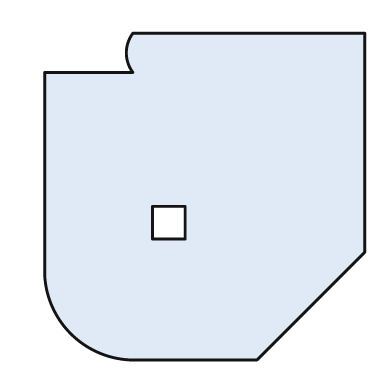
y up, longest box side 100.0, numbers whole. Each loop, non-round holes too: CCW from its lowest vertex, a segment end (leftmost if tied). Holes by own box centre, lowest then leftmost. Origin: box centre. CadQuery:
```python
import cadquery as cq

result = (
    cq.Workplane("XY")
    .moveTo(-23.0, -50.0)
    .lineTo(16.0, -50.0)
    .lineTo(49.0, -17.0)
    .lineTo(49.0, 50.0)
    .lineTo(-22.0, 50.0)
    .threePointArc((-24.0, 44.0), (-22.0, 38.0))
    .lineTo(-49.0, 38.0)
    .lineTo(-49.0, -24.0)
    .threePointArc((-41.0, -42.0), (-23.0, -50.0))
    .close()
    .moveTo(-16.0, -13.0)
    .lineTo(-6.0, -13.0)
    .lineTo(-6.0, -3.0)
    .lineTo(-16.0, -3.0)
    .close()
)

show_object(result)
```